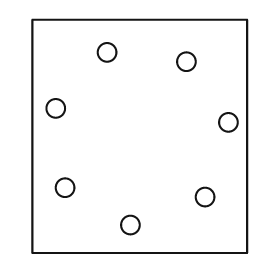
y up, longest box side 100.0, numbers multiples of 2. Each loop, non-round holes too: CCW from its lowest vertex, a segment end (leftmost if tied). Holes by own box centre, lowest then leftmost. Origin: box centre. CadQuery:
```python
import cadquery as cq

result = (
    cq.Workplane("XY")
    .moveTo(-46.0, -50.0)
    .lineTo(46.0, -50.0)
    .lineTo(46.0, 50.0)
    .lineTo(-46.0, 50.0)
    .close()
    .moveTo(-4.0, -38.0)
    .circle(4.0)
    .moveTo(28.0, -26.0)
    .circle(4.0)
    .moveTo(-32.0, -22.0)
    .circle(4.0)
    .moveTo(38.0, 6.0)
    .circle(4.0)
    .moveTo(-36.0, 12.0)
    .circle(4.0)
    .moveTo(20.0, 32.0)
    .circle(4.0)
    .moveTo(-14.0, 36.0)
    .circle(4.0)
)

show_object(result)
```